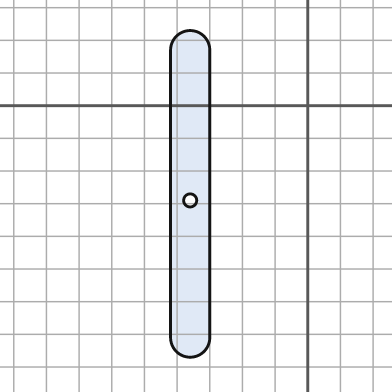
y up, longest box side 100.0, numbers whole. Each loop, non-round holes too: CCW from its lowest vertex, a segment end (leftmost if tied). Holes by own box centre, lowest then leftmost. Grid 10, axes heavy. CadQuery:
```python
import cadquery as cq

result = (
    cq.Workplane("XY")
    .moveTo(-42.0, -71.0)
    .threePointArc((-36.0, -77.0), (-30.0, -71.0))
    .lineTo(-30.0, 17.0)
    .threePointArc((-36.0, 23.0), (-42.0, 17.0))
    .close()
    .moveTo(-36.0, -29.0)
    .circle(2.0)
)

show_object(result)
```